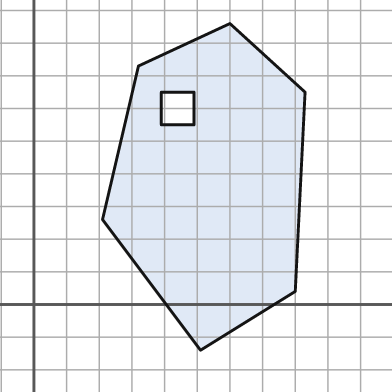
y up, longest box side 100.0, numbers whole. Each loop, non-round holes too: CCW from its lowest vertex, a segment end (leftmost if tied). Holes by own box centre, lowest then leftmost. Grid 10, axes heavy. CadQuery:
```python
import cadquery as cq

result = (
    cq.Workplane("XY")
    .moveTo(51.0, -14.0)
    .lineTo(80.0, 4.0)
    .lineTo(83.0, 65.0)
    .lineTo(60.0, 86.0)
    .lineTo(32.0, 73.0)
    .lineTo(21.0, 26.0)
    .close()
    .moveTo(39.0, 55.0)
    .lineTo(49.0, 55.0)
    .lineTo(49.0, 65.0)
    .lineTo(39.0, 65.0)
    .close()
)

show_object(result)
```